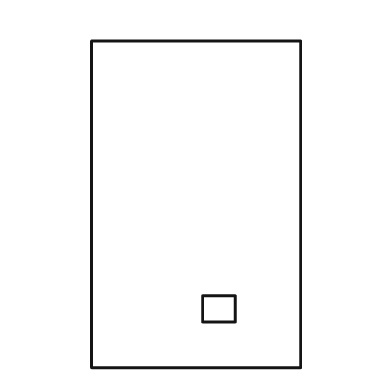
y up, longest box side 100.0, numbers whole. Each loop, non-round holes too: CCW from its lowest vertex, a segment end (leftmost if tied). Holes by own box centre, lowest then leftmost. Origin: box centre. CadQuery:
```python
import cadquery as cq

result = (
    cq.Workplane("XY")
    .moveTo(-32.0, -50.0)
    .lineTo(32.0, -50.0)
    .lineTo(32.0, 50.0)
    .lineTo(-32.0, 50.0)
    .close()
    .moveTo(2.0, -36.0)
    .lineTo(12.0, -36.0)
    .lineTo(12.0, -28.0)
    .lineTo(2.0, -28.0)
    .close()
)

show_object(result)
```